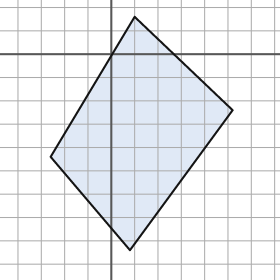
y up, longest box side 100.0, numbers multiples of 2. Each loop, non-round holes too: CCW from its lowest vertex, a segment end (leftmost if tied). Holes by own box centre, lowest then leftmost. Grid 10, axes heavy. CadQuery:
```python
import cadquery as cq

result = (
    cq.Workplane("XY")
    .moveTo(8.0, -84.0)
    .lineTo(52.0, -24.0)
    .lineTo(10.0, 16.0)
    .lineTo(-26.0, -44.0)
    .close()
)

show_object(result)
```